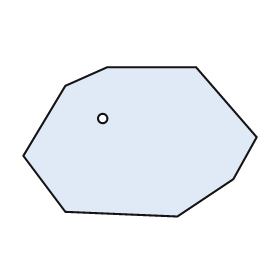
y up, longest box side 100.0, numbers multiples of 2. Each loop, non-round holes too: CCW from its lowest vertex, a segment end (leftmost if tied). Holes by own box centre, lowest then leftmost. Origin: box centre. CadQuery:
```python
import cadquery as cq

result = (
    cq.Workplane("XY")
    .moveTo(16.0, -32.0)
    .lineTo(40.0, -16.0)
    .lineTo(50.0, 2.0)
    .lineTo(24.0, 32.0)
    .lineTo(-14.0, 32.0)
    .lineTo(-32.0, 24.0)
    .lineTo(-50.0, -6.0)
    .lineTo(-32.0, -30.0)
    .close()
    .moveTo(-16.0, 10.0)
    .circle(2.0)
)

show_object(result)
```